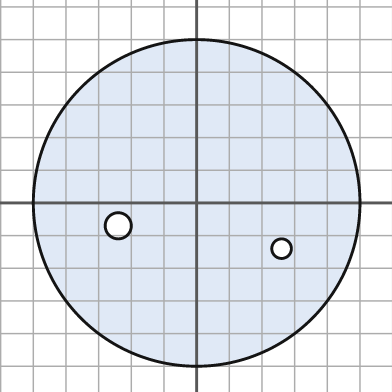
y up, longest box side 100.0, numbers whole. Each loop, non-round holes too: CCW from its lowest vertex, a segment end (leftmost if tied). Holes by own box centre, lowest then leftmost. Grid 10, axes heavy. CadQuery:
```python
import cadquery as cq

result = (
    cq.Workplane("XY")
    .moveTo(0.0, 0.0)
    .circle(50.0)
    .moveTo(26.0, -14.0)
    .circle(3.0)
    .moveTo(-24.0, -7.0)
    .circle(4.0)
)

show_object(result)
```